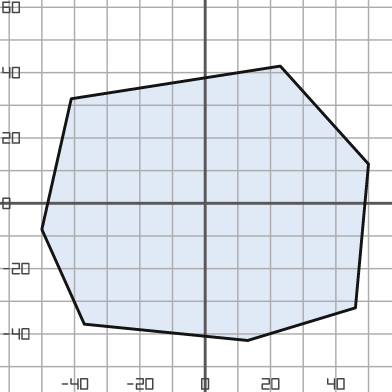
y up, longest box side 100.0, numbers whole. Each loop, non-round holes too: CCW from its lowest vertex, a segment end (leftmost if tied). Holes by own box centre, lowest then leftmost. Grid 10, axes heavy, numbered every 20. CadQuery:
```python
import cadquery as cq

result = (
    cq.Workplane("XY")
    .moveTo(13.0, -42.0)
    .lineTo(46.0, -32.0)
    .lineTo(50.0, 12.0)
    .lineTo(23.0, 42.0)
    .lineTo(-41.0, 32.0)
    .lineTo(-50.0, -8.0)
    .lineTo(-37.0, -37.0)
    .close()
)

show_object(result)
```